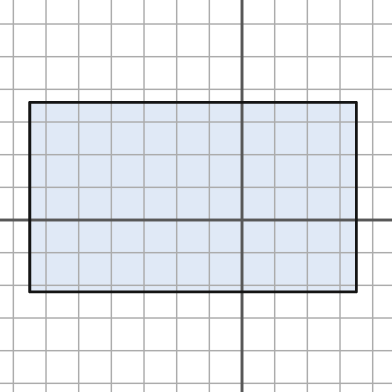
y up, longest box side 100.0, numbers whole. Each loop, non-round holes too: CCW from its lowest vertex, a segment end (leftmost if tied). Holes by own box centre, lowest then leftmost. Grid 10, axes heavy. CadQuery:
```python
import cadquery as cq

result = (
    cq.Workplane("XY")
    .moveTo(-65.0, -22.0)
    .lineTo(35.0, -22.0)
    .lineTo(35.0, 36.0)
    .lineTo(-65.0, 36.0)
    .close()
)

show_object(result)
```